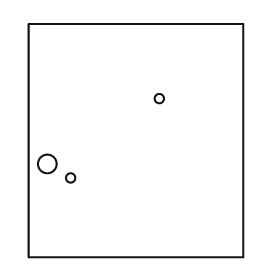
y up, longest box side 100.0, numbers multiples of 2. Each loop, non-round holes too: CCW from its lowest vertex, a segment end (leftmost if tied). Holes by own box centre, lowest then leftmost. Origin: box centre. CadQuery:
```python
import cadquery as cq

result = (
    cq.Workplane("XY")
    .moveTo(-46.0, -50.0)
    .lineTo(46.0, -50.0)
    .lineTo(46.0, 50.0)
    .lineTo(-46.0, 50.0)
    .close()
    .moveTo(-28.0, -16.0)
    .circle(2.0)
    .moveTo(-38.0, -10.0)
    .circle(4.0)
    .moveTo(10.0, 18.0)
    .circle(2.0)
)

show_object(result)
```